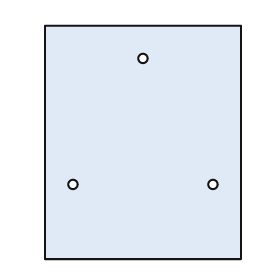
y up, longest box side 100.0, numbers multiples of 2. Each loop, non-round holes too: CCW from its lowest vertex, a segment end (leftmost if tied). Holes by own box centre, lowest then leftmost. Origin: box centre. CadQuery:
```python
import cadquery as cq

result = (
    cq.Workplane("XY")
    .moveTo(-42.0, -50.0)
    .lineTo(42.0, -50.0)
    .lineTo(42.0, 50.0)
    .lineTo(-42.0, 50.0)
    .close()
    .moveTo(-30.0, -18.0)
    .circle(2.0)
    .moveTo(30.0, -18.0)
    .circle(2.0)
    .moveTo(0.0, 36.0)
    .circle(2.0)
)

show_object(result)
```